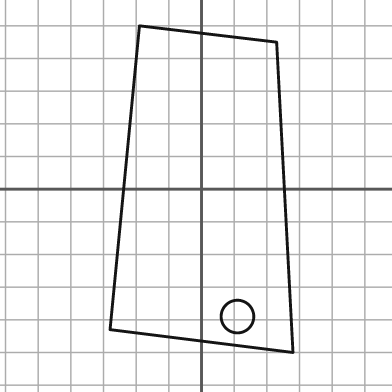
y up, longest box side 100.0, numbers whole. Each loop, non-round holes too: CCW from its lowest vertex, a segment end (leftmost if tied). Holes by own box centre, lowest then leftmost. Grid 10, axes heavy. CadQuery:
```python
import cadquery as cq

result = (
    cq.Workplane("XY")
    .moveTo(28.0, -50.0)
    .lineTo(23.0, 45.0)
    .lineTo(-19.0, 50.0)
    .lineTo(-28.0, -43.0)
    .close()
    .moveTo(11.0, -39.0)
    .circle(5.0)
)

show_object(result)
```